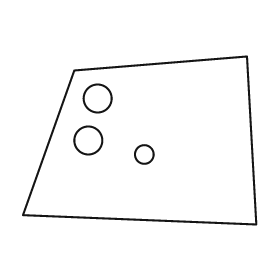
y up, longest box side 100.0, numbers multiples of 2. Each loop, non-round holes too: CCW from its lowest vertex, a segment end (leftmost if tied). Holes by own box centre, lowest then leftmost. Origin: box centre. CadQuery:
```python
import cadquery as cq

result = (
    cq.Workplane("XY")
    .moveTo(50.0, -36.0)
    .lineTo(46.0, 36.0)
    .lineTo(-28.0, 30.0)
    .lineTo(-50.0, -32.0)
    .close()
    .moveTo(2.0, -6.0)
    .circle(4.0)
    .moveTo(-22.0, 0.0)
    .circle(6.0)
    .moveTo(-18.0, 18.0)
    .circle(6.0)
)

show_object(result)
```